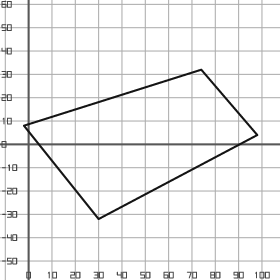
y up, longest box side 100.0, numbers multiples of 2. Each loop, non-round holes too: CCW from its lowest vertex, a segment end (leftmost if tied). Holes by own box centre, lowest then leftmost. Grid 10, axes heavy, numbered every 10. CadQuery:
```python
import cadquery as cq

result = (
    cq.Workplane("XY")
    .moveTo(30.0, -32.0)
    .lineTo(98.0, 4.0)
    .lineTo(74.0, 32.0)
    .lineTo(-2.0, 8.0)
    .close()
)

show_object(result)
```